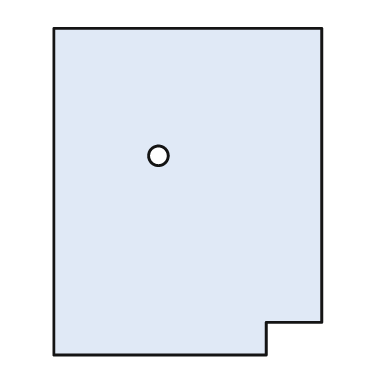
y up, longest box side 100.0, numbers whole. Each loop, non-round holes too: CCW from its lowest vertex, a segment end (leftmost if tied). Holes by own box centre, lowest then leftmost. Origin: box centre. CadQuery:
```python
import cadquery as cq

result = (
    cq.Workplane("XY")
    .moveTo(-41.0, -50.0)
    .lineTo(24.0, -50.0)
    .lineTo(24.0, -40.0)
    .lineTo(41.0, -40.0)
    .lineTo(41.0, 50.0)
    .lineTo(-41.0, 50.0)
    .close()
    .moveTo(-9.0, 11.0)
    .circle(3.0)
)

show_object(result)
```